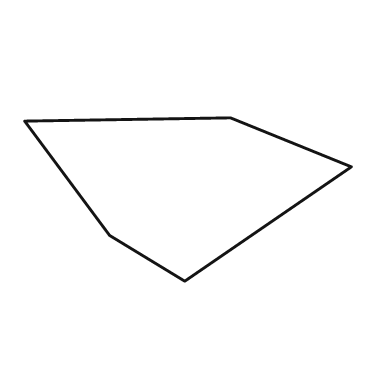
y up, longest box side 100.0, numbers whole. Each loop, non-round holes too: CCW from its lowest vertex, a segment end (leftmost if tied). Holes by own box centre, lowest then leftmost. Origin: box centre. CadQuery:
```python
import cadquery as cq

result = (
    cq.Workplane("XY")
    .moveTo(-1.0, -25.0)
    .lineTo(50.0, 10.0)
    .lineTo(13.0, 25.0)
    .lineTo(-50.0, 24.0)
    .lineTo(-24.0, -11.0)
    .close()
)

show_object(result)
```